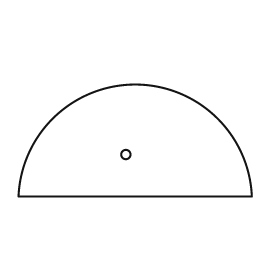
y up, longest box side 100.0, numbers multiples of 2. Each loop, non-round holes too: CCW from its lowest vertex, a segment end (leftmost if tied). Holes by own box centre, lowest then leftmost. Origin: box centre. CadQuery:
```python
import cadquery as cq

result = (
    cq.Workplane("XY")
    .moveTo(-50.0, -24.0)
    .lineTo(50.0, -24.0)
    .threePointArc((0.0, 24.0), (-50.0, -24.0))
    .close()
    .moveTo(-4.0, -6.0)
    .circle(2.0)
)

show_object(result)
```